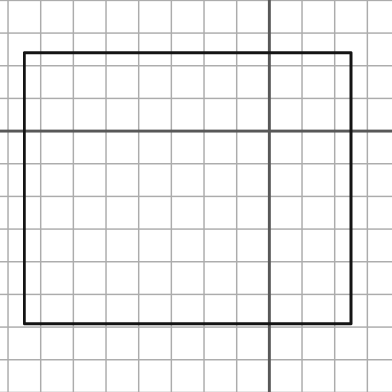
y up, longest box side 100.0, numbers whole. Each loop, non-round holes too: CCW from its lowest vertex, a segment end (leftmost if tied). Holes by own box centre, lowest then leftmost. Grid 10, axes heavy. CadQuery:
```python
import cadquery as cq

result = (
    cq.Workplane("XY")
    .moveTo(-75.0, -59.0)
    .lineTo(25.0, -59.0)
    .lineTo(25.0, 24.0)
    .lineTo(-75.0, 24.0)
    .close()
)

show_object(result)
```